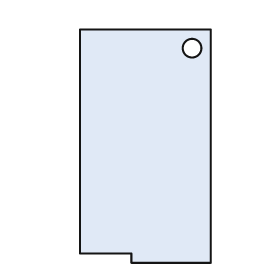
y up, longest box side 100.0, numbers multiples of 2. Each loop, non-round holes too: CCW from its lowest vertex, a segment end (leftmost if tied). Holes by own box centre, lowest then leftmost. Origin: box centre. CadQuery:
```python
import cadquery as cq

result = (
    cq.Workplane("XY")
    .moveTo(-6.0, -50.0)
    .lineTo(28.0, -50.0)
    .lineTo(28.0, 50.0)
    .lineTo(-28.0, 50.0)
    .lineTo(-28.0, -46.0)
    .lineTo(-6.0, -46.0)
    .close()
    .moveTo(20.0, 42.0)
    .circle(4.0)
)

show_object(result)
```